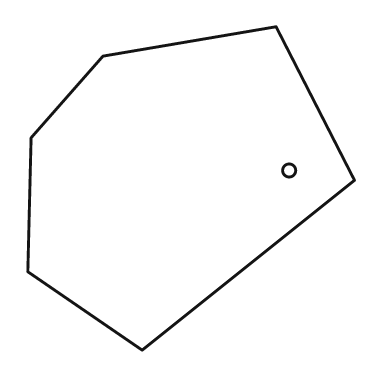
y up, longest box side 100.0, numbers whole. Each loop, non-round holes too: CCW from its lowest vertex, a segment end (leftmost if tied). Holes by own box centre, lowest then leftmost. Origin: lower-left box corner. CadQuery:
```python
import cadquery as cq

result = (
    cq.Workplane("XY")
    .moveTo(35.0, 0.0)
    .lineTo(100.0, 52.0)
    .lineTo(76.0, 99.0)
    .lineTo(23.0, 90.0)
    .lineTo(1.0, 65.0)
    .lineTo(0.0, 24.0)
    .close()
    .moveTo(80.0, 55.0)
    .circle(2.0)
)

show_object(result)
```